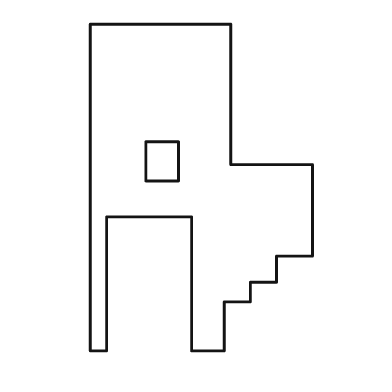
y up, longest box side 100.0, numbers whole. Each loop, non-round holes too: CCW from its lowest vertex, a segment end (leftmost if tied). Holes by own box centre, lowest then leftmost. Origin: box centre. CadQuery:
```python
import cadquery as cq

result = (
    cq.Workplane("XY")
    .moveTo(-34.0, -50.0)
    .lineTo(-29.0, -50.0)
    .lineTo(-29.0, -9.0)
    .lineTo(-3.0, -9.0)
    .lineTo(-3.0, -50.0)
    .lineTo(7.0, -50.0)
    .lineTo(7.0, -35.0)
    .lineTo(15.0, -35.0)
    .lineTo(15.0, -29.0)
    .lineTo(23.0, -29.0)
    .lineTo(23.0, -21.0)
    .lineTo(34.0, -21.0)
    .lineTo(34.0, 7.0)
    .lineTo(9.0, 7.0)
    .lineTo(9.0, 50.0)
    .lineTo(-34.0, 50.0)
    .close()
    .moveTo(-17.0, 2.0)
    .lineTo(-7.0, 2.0)
    .lineTo(-7.0, 14.0)
    .lineTo(-17.0, 14.0)
    .close()
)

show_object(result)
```